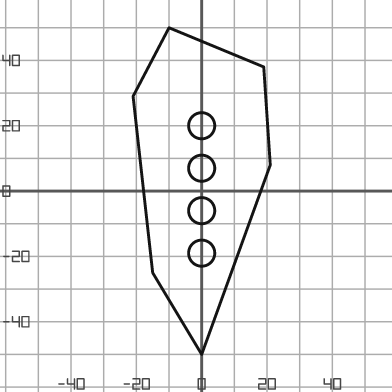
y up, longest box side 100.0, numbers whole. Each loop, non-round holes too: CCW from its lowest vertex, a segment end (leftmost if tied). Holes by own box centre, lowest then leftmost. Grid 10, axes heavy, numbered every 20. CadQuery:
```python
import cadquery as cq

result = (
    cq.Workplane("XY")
    .moveTo(0.0, -50.0)
    .lineTo(21.0, 8.0)
    .lineTo(19.0, 38.0)
    .lineTo(-10.0, 50.0)
    .lineTo(-21.0, 29.0)
    .lineTo(-15.0, -25.0)
    .close()
    .moveTo(0.0, -19.0)
    .circle(4.0)
    .moveTo(0.0, -6.0)
    .circle(4.0)
    .moveTo(0.0, 7.0)
    .circle(4.0)
    .moveTo(0.0, 20.0)
    .circle(4.0)
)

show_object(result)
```